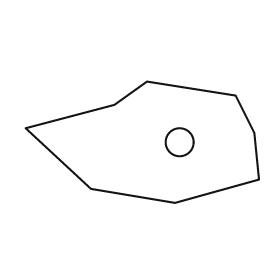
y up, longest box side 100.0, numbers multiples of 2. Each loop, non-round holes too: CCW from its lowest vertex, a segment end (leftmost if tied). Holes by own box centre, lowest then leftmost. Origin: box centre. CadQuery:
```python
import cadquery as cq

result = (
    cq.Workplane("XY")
    .moveTo(14.0, -26.0)
    .lineTo(50.0, -16.0)
    .lineTo(48.0, 4.0)
    .lineTo(40.0, 20.0)
    .lineTo(2.0, 26.0)
    .lineTo(-12.0, 16.0)
    .lineTo(-50.0, 6.0)
    .lineTo(-22.0, -20.0)
    .close()
    .moveTo(16.0, 0.0)
    .circle(6.0)
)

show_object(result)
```